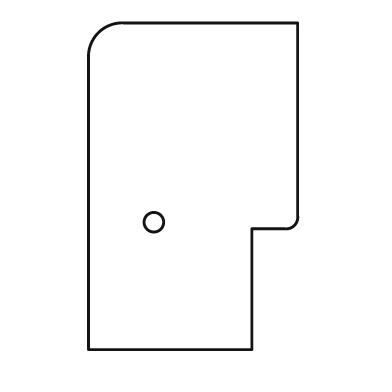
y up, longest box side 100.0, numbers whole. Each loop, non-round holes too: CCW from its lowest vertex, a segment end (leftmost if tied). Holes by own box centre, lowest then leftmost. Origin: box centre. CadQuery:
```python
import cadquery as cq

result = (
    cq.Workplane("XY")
    .moveTo(-32.0, -50.0)
    .lineTo(18.0, -50.0)
    .lineTo(18.0, -13.0)
    .lineTo(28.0, -13.0)
    .threePointArc((31.0, -12.0), (32.0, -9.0))
    .lineTo(32.0, 50.0)
    .lineTo(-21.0, 50.0)
    .threePointArc((-29.0, 47.0), (-32.0, 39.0))
    .close()
    .moveTo(-12.0, -11.0)
    .circle(3.0)
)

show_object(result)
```